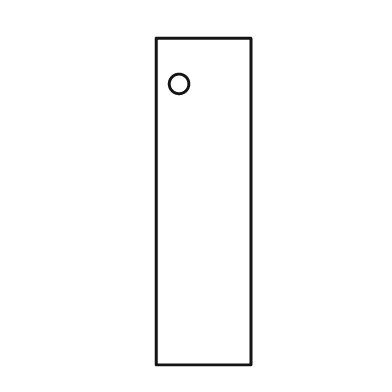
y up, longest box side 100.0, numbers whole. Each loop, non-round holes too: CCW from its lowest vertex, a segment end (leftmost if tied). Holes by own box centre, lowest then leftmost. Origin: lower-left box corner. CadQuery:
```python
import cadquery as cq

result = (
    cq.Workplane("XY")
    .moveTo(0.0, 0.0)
    .lineTo(29.0, 0.0)
    .lineTo(29.0, 100.0)
    .lineTo(0.0, 100.0)
    .close()
    .moveTo(7.0, 86.0)
    .circle(3.0)
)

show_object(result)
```